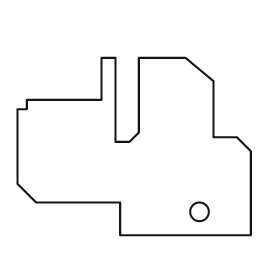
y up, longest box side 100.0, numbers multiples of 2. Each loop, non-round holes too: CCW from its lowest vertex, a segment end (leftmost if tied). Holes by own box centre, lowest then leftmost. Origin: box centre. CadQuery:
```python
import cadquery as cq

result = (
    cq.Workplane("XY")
    .moveTo(-6.0, -38.0)
    .lineTo(50.0, -38.0)
    .lineTo(50.0, -2.0)
    .lineTo(44.0, 4.0)
    .lineTo(34.0, 4.0)
    .lineTo(34.0, 28.0)
    .lineTo(22.0, 38.0)
    .lineTo(2.0, 38.0)
    .lineTo(2.0, 6.0)
    .lineTo(-2.0, 2.0)
    .lineTo(-8.0, 2.0)
    .lineTo(-8.0, 38.0)
    .lineTo(-14.0, 38.0)
    .lineTo(-14.0, 20.0)
    .lineTo(-46.0, 20.0)
    .lineTo(-46.0, 16.0)
    .lineTo(-50.0, 16.0)
    .lineTo(-50.0, -16.0)
    .lineTo(-42.0, -24.0)
    .lineTo(-6.0, -24.0)
    .close()
    .moveTo(28.0, -28.0)
    .circle(4.0)
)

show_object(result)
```